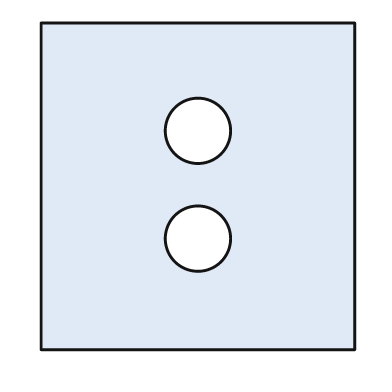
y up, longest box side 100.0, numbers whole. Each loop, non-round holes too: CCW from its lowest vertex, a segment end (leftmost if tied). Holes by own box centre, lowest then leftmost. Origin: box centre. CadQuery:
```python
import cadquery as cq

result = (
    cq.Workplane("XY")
    .moveTo(-48.0, -50.0)
    .lineTo(48.0, -50.0)
    .lineTo(48.0, 50.0)
    .lineTo(-48.0, 50.0)
    .close()
    .moveTo(0.0, -16.0)
    .circle(10.0)
    .moveTo(0.0, 17.0)
    .circle(10.0)
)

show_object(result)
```